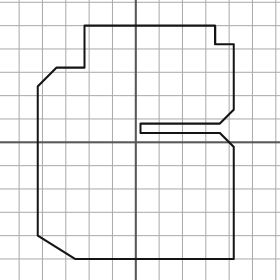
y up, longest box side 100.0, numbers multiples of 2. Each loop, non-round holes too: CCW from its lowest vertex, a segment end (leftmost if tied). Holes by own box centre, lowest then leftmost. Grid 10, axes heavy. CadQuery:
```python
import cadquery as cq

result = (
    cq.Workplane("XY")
    .moveTo(-26.0, -50.0)
    .lineTo(42.0, -50.0)
    .lineTo(42.0, -2.0)
    .lineTo(36.0, 4.0)
    .lineTo(2.0, 4.0)
    .lineTo(2.0, 8.0)
    .lineTo(36.0, 8.0)
    .lineTo(42.0, 14.0)
    .lineTo(42.0, 42.0)
    .lineTo(34.0, 42.0)
    .lineTo(34.0, 50.0)
    .lineTo(-22.0, 50.0)
    .lineTo(-22.0, 32.0)
    .lineTo(-34.0, 32.0)
    .lineTo(-42.0, 24.0)
    .lineTo(-42.0, -40.0)
    .close()
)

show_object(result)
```